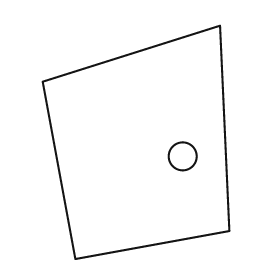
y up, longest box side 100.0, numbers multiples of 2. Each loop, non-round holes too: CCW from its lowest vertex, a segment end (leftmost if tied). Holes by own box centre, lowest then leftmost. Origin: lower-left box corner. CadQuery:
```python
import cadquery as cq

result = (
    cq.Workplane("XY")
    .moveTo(14.0, 0.0)
    .lineTo(80.0, 12.0)
    .lineTo(76.0, 100.0)
    .lineTo(0.0, 76.0)
    .close()
    .moveTo(60.0, 44.0)
    .circle(6.0)
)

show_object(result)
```